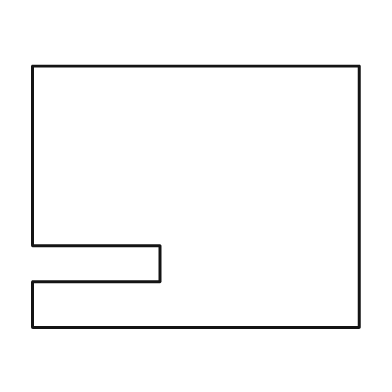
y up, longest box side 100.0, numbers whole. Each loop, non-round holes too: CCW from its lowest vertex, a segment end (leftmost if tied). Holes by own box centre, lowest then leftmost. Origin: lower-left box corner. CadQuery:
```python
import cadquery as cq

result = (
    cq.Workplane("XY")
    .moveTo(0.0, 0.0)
    .lineTo(100.0, 0.0)
    .lineTo(100.0, 80.0)
    .lineTo(0.0, 80.0)
    .lineTo(0.0, 25.0)
    .lineTo(39.0, 25.0)
    .lineTo(39.0, 14.0)
    .lineTo(0.0, 14.0)
    .close()
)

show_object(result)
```